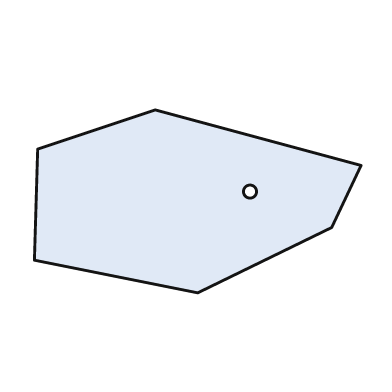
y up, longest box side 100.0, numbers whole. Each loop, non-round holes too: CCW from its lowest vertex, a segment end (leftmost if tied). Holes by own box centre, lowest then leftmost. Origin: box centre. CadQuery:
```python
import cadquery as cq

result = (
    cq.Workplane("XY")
    .moveTo(0.0, -28.0)
    .lineTo(41.0, -8.0)
    .lineTo(50.0, 11.0)
    .lineTo(-13.0, 28.0)
    .lineTo(-49.0, 16.0)
    .lineTo(-50.0, -18.0)
    .close()
    .moveTo(16.0, 3.0)
    .circle(2.0)
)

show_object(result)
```